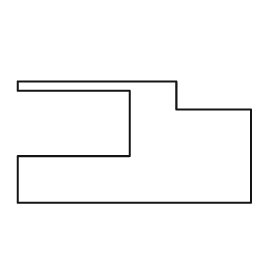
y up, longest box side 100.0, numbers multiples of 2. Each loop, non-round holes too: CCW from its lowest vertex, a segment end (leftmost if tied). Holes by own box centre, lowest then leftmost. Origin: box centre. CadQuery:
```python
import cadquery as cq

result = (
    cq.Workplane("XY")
    .moveTo(-50.0, -26.0)
    .lineTo(50.0, -26.0)
    .lineTo(50.0, 14.0)
    .lineTo(18.0, 14.0)
    .lineTo(18.0, 26.0)
    .lineTo(-50.0, 26.0)
    .lineTo(-50.0, 22.0)
    .lineTo(-2.0, 22.0)
    .lineTo(-2.0, -6.0)
    .lineTo(-50.0, -6.0)
    .close()
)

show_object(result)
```